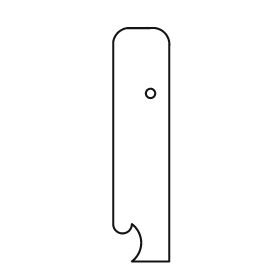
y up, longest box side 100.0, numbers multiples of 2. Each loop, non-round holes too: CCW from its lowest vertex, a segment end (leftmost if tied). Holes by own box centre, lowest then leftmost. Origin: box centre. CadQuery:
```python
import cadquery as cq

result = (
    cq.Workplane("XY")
    .moveTo(-4.0, -50.0)
    .lineTo(12.0, -50.0)
    .lineTo(12.0, 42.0)
    .threePointArc((10.0, 48.0), (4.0, 50.0))
    .lineTo(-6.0, 50.0)
    .threePointArc((-10.0, 48.0), (-12.0, 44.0))
    .lineTo(-12.0, -34.0)
    .threePointArc((-8.0, -38.0), (-4.0, -34.0))
    .threePointArc((0.0, -42.0), (-4.0, -50.0))
    .close()
    .moveTo(4.0, 22.0)
    .circle(2.0)
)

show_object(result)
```